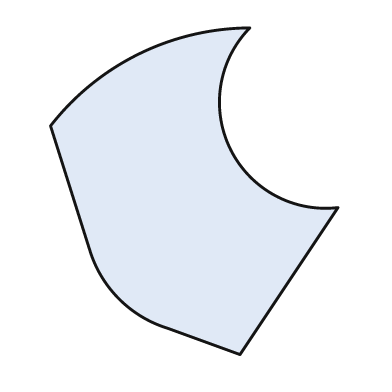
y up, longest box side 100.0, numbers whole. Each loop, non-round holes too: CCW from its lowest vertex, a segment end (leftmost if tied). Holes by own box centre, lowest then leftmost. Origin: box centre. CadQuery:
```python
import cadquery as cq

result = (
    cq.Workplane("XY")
    .moveTo(14.0, -50.0)
    .lineTo(44.0, -5.0)
    .threePointArc((11.0, 13.0), (17.0, 50.0))
    .threePointArc((-17.0, 42.0), (-44.0, 20.0))
    .lineTo(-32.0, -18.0)
    .threePointArc((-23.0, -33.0), (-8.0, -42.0))
    .close()
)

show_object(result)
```